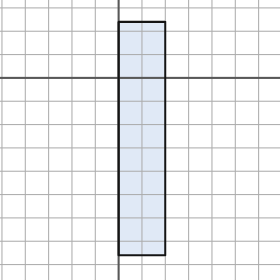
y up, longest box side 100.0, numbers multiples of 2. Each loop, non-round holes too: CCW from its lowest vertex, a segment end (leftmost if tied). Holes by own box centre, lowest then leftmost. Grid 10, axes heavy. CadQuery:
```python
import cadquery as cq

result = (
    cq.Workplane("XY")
    .moveTo(0.0, -76.0)
    .lineTo(20.0, -76.0)
    .lineTo(20.0, 24.0)
    .lineTo(0.0, 24.0)
    .close()
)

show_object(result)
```